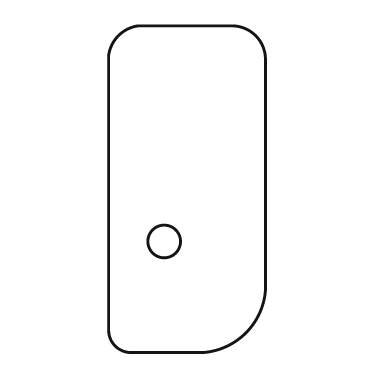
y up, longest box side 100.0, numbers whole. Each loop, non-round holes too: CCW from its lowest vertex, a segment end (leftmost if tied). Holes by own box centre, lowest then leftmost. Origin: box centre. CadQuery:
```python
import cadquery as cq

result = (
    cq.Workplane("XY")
    .moveTo(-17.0, -50.0)
    .lineTo(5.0, -50.0)
    .threePointArc((18.0, -44.0), (24.0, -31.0))
    .lineTo(24.0, 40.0)
    .threePointArc((21.0, 47.0), (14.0, 50.0))
    .lineTo(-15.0, 50.0)
    .threePointArc((-21.0, 47.0), (-24.0, 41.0))
    .lineTo(-24.0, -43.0)
    .threePointArc((-22.0, -48.0), (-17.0, -50.0))
    .close()
    .moveTo(-7.0, -16.0)
    .circle(5.0)
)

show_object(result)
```